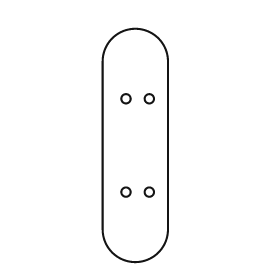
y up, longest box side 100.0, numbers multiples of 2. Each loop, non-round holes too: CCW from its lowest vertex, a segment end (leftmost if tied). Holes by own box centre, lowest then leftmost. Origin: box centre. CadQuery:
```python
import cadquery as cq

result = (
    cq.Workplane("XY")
    .moveTo(-14.0, -36.0)
    .threePointArc((0.0, -50.0), (14.0, -36.0))
    .lineTo(14.0, 36.0)
    .threePointArc((0.0, 50.0), (-14.0, 36.0))
    .close()
    .moveTo(-4.0, -20.0)
    .circle(2.0)
    .moveTo(6.0, -20.0)
    .circle(2.0)
    .moveTo(-4.0, 20.0)
    .circle(2.0)
    .moveTo(6.0, 20.0)
    .circle(2.0)
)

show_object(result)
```